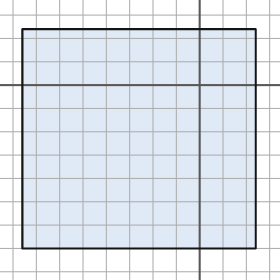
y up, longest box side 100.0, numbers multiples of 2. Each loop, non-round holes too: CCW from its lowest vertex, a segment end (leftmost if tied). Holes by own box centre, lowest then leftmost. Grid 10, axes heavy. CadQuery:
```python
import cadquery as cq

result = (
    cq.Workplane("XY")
    .moveTo(-76.0, -70.0)
    .lineTo(24.0, -70.0)
    .lineTo(24.0, 24.0)
    .lineTo(-76.0, 24.0)
    .close()
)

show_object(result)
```